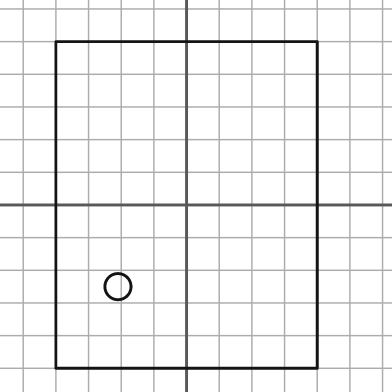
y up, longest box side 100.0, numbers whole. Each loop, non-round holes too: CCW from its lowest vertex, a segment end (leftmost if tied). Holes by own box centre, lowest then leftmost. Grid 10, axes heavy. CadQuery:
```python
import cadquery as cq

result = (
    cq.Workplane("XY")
    .moveTo(-40.0, -50.0)
    .lineTo(40.0, -50.0)
    .lineTo(40.0, 50.0)
    .lineTo(-40.0, 50.0)
    .close()
    .moveTo(-21.0, -25.0)
    .circle(4.0)
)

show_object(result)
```